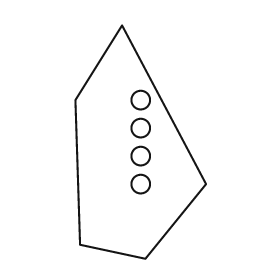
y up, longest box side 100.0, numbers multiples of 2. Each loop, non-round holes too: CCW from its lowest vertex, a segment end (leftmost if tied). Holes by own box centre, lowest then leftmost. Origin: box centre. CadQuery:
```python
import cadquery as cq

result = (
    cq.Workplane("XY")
    .moveTo(2.0, -50.0)
    .lineTo(28.0, -18.0)
    .lineTo(-8.0, 50.0)
    .lineTo(-28.0, 18.0)
    .lineTo(-26.0, -44.0)
    .close()
    .moveTo(0.0, -18.0)
    .circle(4.0)
    .moveTo(0.0, -6.0)
    .circle(4.0)
    .moveTo(0.0, 6.0)
    .circle(4.0)
    .moveTo(0.0, 18.0)
    .circle(4.0)
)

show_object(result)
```